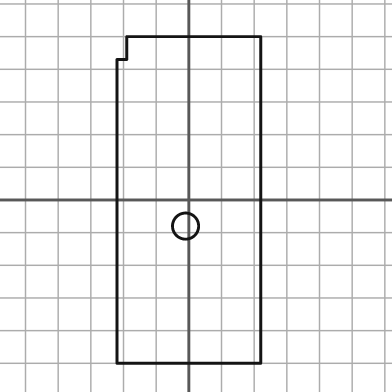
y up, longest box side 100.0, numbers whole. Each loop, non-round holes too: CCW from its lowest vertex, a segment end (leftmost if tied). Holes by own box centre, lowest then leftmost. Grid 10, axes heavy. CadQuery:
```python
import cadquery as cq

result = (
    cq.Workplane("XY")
    .moveTo(-22.0, -50.0)
    .lineTo(22.0, -50.0)
    .lineTo(22.0, 50.0)
    .lineTo(-19.0, 50.0)
    .lineTo(-19.0, 43.0)
    .lineTo(-22.0, 43.0)
    .close()
    .moveTo(-1.0, -8.0)
    .circle(4.0)
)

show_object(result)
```